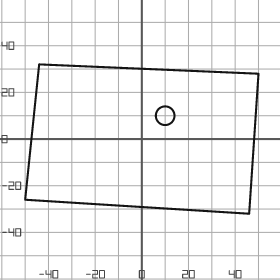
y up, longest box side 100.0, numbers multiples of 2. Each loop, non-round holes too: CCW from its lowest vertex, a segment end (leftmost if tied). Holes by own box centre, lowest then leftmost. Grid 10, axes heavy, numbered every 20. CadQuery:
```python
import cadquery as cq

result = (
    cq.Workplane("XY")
    .moveTo(46.0, -32.0)
    .lineTo(50.0, 28.0)
    .lineTo(-44.0, 32.0)
    .lineTo(-50.0, -26.0)
    .close()
    .moveTo(10.0, 10.0)
    .circle(4.0)
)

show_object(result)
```